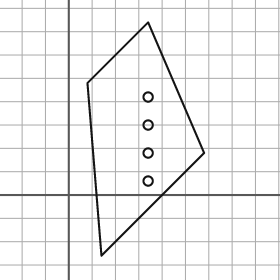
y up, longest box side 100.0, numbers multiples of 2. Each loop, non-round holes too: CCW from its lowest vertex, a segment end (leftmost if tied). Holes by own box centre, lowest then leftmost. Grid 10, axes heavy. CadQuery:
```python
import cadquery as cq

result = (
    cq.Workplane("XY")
    .moveTo(14.0, -26.0)
    .lineTo(58.0, 18.0)
    .lineTo(34.0, 74.0)
    .lineTo(8.0, 48.0)
    .close()
    .moveTo(34.0, 6.0)
    .circle(2.0)
    .moveTo(34.0, 18.0)
    .circle(2.0)
    .moveTo(34.0, 30.0)
    .circle(2.0)
    .moveTo(34.0, 42.0)
    .circle(2.0)
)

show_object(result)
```